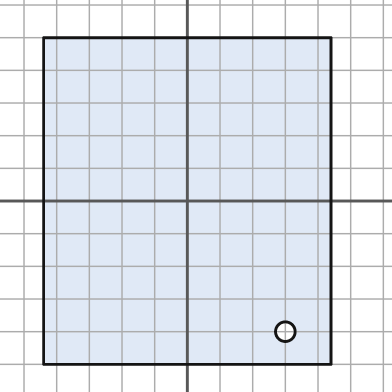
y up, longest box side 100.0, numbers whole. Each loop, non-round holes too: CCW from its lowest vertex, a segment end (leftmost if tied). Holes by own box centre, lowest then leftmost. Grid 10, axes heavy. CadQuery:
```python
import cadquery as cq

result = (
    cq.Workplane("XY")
    .moveTo(-44.0, -50.0)
    .lineTo(44.0, -50.0)
    .lineTo(44.0, 50.0)
    .lineTo(-44.0, 50.0)
    .close()
    .moveTo(30.0, -40.0)
    .circle(3.0)
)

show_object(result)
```